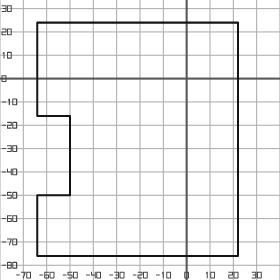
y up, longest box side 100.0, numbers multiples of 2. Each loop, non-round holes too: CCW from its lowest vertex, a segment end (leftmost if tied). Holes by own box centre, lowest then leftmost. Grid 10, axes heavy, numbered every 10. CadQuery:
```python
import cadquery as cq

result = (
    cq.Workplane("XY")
    .moveTo(-64.0, -76.0)
    .lineTo(22.0, -76.0)
    .lineTo(22.0, 24.0)
    .lineTo(-64.0, 24.0)
    .lineTo(-64.0, -16.0)
    .lineTo(-50.0, -16.0)
    .lineTo(-50.0, -50.0)
    .lineTo(-64.0, -50.0)
    .close()
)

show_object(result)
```